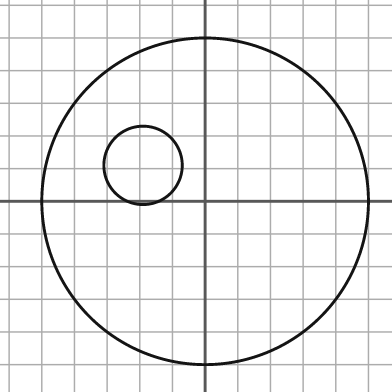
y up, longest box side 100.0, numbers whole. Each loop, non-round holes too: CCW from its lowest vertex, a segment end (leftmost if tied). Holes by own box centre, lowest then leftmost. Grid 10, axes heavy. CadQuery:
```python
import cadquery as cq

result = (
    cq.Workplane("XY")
    .moveTo(0.0, 0.0)
    .circle(50.0)
    .moveTo(-19.0, 11.0)
    .circle(12.0)
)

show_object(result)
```